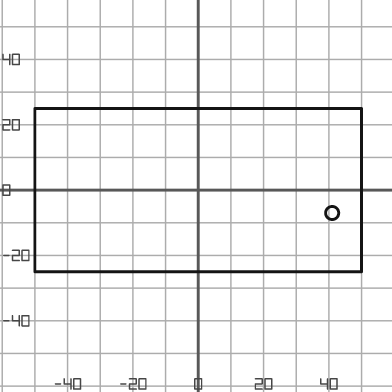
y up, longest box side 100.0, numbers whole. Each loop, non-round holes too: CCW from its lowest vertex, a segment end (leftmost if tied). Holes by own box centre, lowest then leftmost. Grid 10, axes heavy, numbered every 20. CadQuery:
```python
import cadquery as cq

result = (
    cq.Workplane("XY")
    .moveTo(-50.0, -25.0)
    .lineTo(50.0, -25.0)
    .lineTo(50.0, 25.0)
    .lineTo(-50.0, 25.0)
    .close()
    .moveTo(41.0, -7.0)
    .circle(2.0)
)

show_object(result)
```